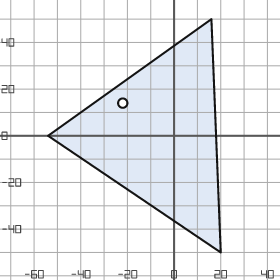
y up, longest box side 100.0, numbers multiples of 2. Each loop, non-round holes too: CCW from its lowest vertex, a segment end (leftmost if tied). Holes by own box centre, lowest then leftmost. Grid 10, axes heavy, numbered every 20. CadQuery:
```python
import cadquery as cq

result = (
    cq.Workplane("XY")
    .moveTo(20.0, -50.0)
    .lineTo(16.0, 50.0)
    .lineTo(-54.0, 0.0)
    .close()
    .moveTo(-22.0, 14.0)
    .circle(2.0)
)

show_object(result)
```